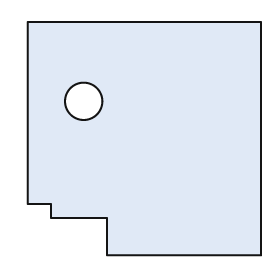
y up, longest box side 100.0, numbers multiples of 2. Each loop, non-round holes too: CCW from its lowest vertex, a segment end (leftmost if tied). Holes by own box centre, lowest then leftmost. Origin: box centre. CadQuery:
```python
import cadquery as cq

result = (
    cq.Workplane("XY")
    .moveTo(-16.0, -50.0)
    .lineTo(50.0, -50.0)
    .lineTo(50.0, 50.0)
    .lineTo(-50.0, 50.0)
    .lineTo(-50.0, -28.0)
    .lineTo(-40.0, -28.0)
    .lineTo(-40.0, -34.0)
    .lineTo(-16.0, -34.0)
    .close()
    .moveTo(-26.0, 16.0)
    .circle(8.0)
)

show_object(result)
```